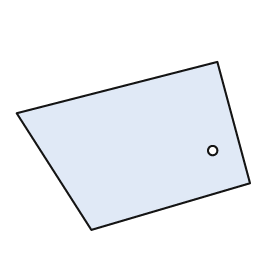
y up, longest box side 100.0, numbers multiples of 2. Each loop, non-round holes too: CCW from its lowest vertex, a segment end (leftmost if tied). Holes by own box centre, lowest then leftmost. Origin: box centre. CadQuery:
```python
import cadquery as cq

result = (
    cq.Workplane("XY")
    .moveTo(-18.0, -36.0)
    .lineTo(50.0, -16.0)
    .lineTo(36.0, 36.0)
    .lineTo(-50.0, 14.0)
    .close()
    .moveTo(34.0, -2.0)
    .circle(2.0)
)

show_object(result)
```